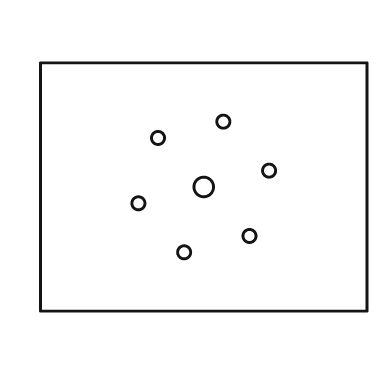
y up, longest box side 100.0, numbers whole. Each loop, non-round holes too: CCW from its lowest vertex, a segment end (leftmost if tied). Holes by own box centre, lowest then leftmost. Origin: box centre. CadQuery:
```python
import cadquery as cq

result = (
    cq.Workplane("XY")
    .moveTo(-50.0, -38.0)
    .lineTo(50.0, -38.0)
    .lineTo(50.0, 38.0)
    .lineTo(-50.0, 38.0)
    .close()
    .moveTo(-6.0, -20.0)
    .circle(2.0)
    .moveTo(14.0, -15.0)
    .circle(2.0)
    .moveTo(-20.0, -5.0)
    .circle(2.0)
    .moveTo(0.0, 0.0)
    .circle(3.0)
    .moveTo(20.0, 5.0)
    .circle(2.0)
    .moveTo(-14.0, 15.0)
    .circle(2.0)
    .moveTo(6.0, 20.0)
    .circle(2.0)
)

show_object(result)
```